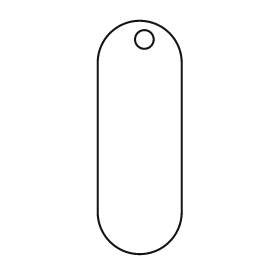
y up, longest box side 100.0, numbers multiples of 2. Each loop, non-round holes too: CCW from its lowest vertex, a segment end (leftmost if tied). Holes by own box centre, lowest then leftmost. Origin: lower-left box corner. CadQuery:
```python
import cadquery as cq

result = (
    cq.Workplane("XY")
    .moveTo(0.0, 18.0)
    .threePointArc((18.0, 0.0), (36.0, 18.0))
    .lineTo(36.0, 82.0)
    .threePointArc((18.0, 100.0), (0.0, 82.0))
    .close()
    .moveTo(20.0, 92.0)
    .circle(4.0)
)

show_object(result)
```